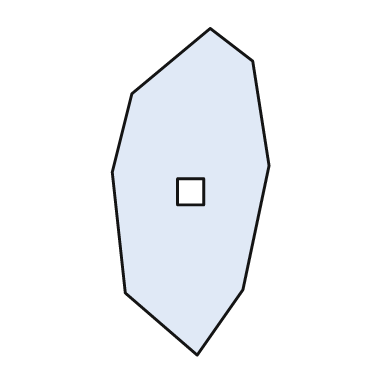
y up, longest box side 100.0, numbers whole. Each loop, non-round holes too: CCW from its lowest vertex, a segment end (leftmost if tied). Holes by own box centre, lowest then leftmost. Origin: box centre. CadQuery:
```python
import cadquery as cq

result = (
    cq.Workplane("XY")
    .moveTo(2.0, -50.0)
    .lineTo(16.0, -30.0)
    .lineTo(24.0, 8.0)
    .lineTo(19.0, 40.0)
    .lineTo(6.0, 50.0)
    .lineTo(-18.0, 30.0)
    .lineTo(-24.0, 6.0)
    .lineTo(-20.0, -31.0)
    .close()
    .moveTo(-4.0, -4.0)
    .lineTo(4.0, -4.0)
    .lineTo(4.0, 4.0)
    .lineTo(-4.0, 4.0)
    .close()
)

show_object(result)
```